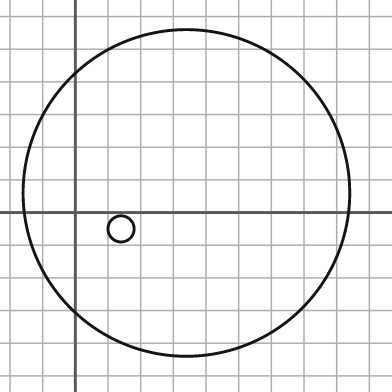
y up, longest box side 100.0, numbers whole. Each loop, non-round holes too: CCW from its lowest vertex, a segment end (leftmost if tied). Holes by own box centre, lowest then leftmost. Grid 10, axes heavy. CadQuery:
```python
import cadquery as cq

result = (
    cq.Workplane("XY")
    .moveTo(34.0, 6.0)
    .circle(50.0)
    .moveTo(14.0, -5.0)
    .circle(4.0)
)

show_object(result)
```